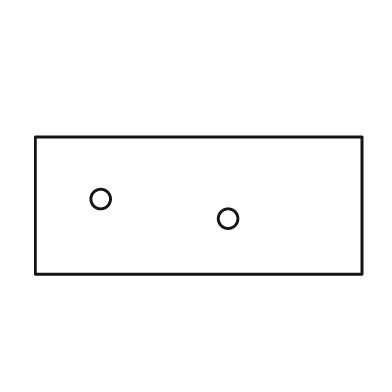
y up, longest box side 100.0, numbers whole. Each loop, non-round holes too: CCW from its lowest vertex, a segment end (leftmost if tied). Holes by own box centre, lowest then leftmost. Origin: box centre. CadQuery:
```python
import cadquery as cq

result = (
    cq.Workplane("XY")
    .moveTo(-50.0, -21.0)
    .lineTo(50.0, -21.0)
    .lineTo(50.0, 21.0)
    .lineTo(-50.0, 21.0)
    .close()
    .moveTo(9.0, -4.0)
    .circle(3.0)
    .moveTo(-30.0, 2.0)
    .circle(3.0)
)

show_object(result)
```